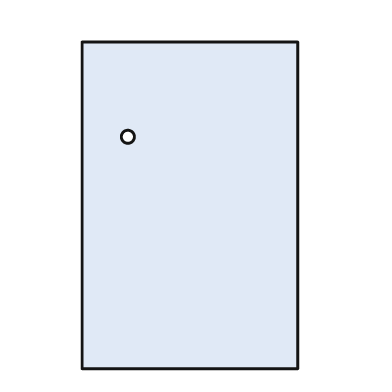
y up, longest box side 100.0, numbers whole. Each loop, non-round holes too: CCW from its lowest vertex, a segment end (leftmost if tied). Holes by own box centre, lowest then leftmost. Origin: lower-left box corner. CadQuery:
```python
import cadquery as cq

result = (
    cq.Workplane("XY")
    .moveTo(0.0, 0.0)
    .lineTo(66.0, 0.0)
    .lineTo(66.0, 100.0)
    .lineTo(0.0, 100.0)
    .close()
    .moveTo(14.0, 71.0)
    .circle(2.0)
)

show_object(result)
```